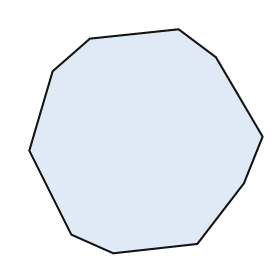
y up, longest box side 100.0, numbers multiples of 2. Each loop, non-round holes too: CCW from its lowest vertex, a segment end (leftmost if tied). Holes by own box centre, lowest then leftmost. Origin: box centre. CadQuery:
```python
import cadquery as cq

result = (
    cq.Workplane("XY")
    .moveTo(-14.0, -48.0)
    .lineTo(22.0, -44.0)
    .lineTo(42.0, -18.0)
    .lineTo(50.0, 2.0)
    .lineTo(30.0, 36.0)
    .lineTo(14.0, 48.0)
    .lineTo(-24.0, 44.0)
    .lineTo(-40.0, 30.0)
    .lineTo(-50.0, -4.0)
    .lineTo(-32.0, -40.0)
    .close()
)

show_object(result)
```